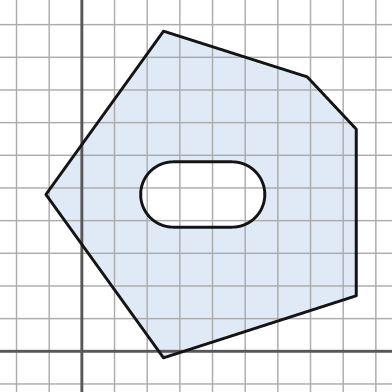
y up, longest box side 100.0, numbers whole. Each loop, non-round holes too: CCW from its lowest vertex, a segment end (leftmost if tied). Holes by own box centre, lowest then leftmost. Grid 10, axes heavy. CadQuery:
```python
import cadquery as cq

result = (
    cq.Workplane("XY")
    .moveTo(25.0, -2.0)
    .lineTo(84.0, 17.0)
    .lineTo(84.0, 68.0)
    .lineTo(69.0, 84.0)
    .lineTo(25.0, 98.0)
    .lineTo(-11.0, 48.0)
    .close()
    .moveTo(28.0, 38.0)
    .lineTo(46.0, 38.0)
    .threePointArc((56.0, 48.0), (46.0, 58.0))
    .lineTo(28.0, 58.0)
    .threePointArc((18.0, 48.0), (28.0, 38.0))
    .close()
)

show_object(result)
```